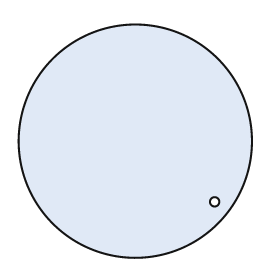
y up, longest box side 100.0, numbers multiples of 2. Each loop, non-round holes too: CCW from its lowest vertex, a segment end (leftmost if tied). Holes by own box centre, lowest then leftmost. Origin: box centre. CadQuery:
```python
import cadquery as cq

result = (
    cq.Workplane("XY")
    .moveTo(0.0, 0.0)
    .circle(50.0)
    .moveTo(34.0, -26.0)
    .circle(2.0)
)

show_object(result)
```